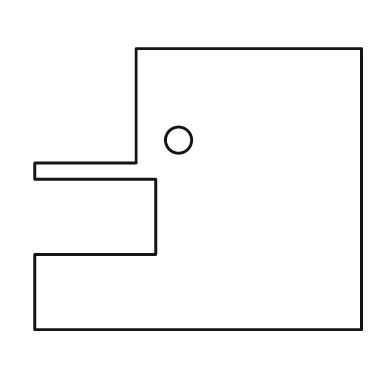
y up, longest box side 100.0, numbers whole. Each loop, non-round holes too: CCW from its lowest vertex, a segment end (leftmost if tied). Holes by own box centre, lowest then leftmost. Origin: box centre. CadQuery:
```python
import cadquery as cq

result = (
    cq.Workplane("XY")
    .moveTo(-50.0, -43.0)
    .lineTo(50.0, -43.0)
    .lineTo(50.0, 43.0)
    .lineTo(-19.0, 43.0)
    .lineTo(-19.0, 8.0)
    .lineTo(-50.0, 8.0)
    .lineTo(-50.0, 3.0)
    .lineTo(-13.0, 3.0)
    .lineTo(-13.0, -20.0)
    .lineTo(-50.0, -20.0)
    .close()
    .moveTo(-6.0, 15.0)
    .circle(4.0)
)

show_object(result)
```